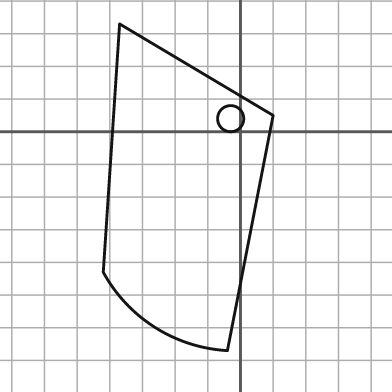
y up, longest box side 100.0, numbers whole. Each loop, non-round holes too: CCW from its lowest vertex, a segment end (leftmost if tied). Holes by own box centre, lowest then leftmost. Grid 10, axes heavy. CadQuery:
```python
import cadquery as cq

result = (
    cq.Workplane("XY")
    .moveTo(-4.0, -67.0)
    .lineTo(10.0, 5.0)
    .lineTo(-37.0, 33.0)
    .lineTo(-42.0, -43.0)
    .threePointArc((-26.0, -60.0), (-4.0, -67.0))
    .close()
    .moveTo(-3.0, 4.0)
    .circle(4.0)
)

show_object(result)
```